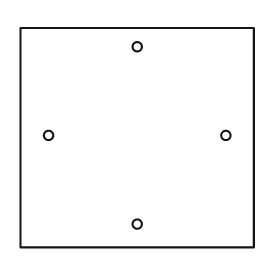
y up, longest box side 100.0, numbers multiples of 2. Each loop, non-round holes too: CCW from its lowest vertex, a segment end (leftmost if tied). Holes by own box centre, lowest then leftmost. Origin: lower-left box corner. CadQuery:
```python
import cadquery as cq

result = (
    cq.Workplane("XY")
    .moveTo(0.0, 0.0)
    .lineTo(100.0, 0.0)
    .lineTo(100.0, 94.0)
    .lineTo(0.0, 94.0)
    .close()
    .moveTo(50.0, 10.0)
    .circle(2.0)
    .moveTo(12.0, 48.0)
    .circle(2.0)
    .moveTo(88.0, 48.0)
    .circle(2.0)
    .moveTo(50.0, 86.0)
    .circle(2.0)
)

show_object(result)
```